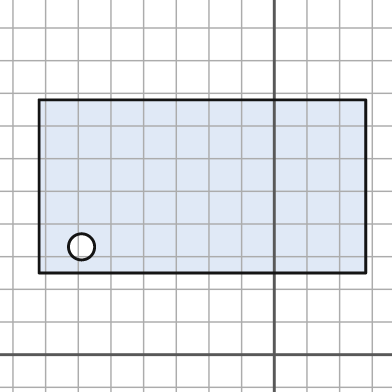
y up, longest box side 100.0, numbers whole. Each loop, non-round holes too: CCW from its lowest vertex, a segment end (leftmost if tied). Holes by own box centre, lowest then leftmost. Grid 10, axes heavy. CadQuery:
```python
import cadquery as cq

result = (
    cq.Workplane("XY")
    .moveTo(-72.0, 25.0)
    .lineTo(28.0, 25.0)
    .lineTo(28.0, 78.0)
    .lineTo(-72.0, 78.0)
    .close()
    .moveTo(-59.0, 33.0)
    .circle(4.0)
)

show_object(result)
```